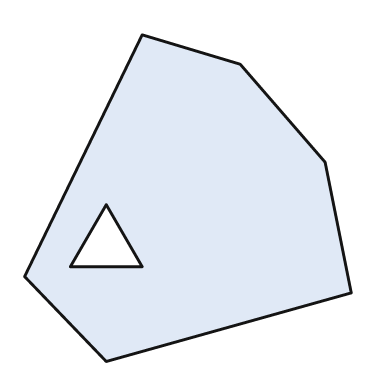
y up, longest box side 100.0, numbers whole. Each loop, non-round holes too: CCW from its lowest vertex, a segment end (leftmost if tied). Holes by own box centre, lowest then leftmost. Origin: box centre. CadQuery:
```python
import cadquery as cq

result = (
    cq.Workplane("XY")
    .moveTo(-25.0, -50.0)
    .lineTo(50.0, -29.0)
    .lineTo(42.0, 11.0)
    .lineTo(16.0, 41.0)
    .lineTo(-14.0, 50.0)
    .lineTo(-50.0, -24.0)
    .close()
    .moveTo(-36.0, -21.0)
    .lineTo(-14.0, -21.0)
    .lineTo(-25.0, -2.0)
    .close()
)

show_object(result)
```